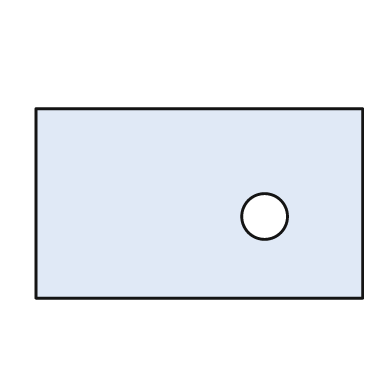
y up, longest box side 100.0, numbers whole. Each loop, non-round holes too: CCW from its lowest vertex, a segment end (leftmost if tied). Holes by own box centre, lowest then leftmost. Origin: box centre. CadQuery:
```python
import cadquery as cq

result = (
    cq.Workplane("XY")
    .moveTo(-50.0, -29.0)
    .lineTo(50.0, -29.0)
    .lineTo(50.0, 29.0)
    .lineTo(-50.0, 29.0)
    .close()
    .moveTo(20.0, -4.0)
    .circle(7.0)
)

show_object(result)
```